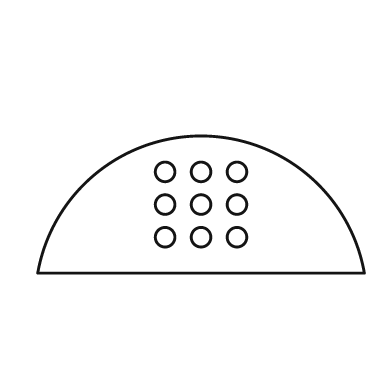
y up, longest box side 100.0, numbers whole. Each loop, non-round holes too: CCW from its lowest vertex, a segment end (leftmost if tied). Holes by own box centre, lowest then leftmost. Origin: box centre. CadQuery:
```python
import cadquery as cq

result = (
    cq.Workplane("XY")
    .moveTo(-50.0, -21.0)
    .lineTo(50.0, -21.0)
    .threePointArc((0.0, 21.0), (-50.0, -21.0))
    .close()
    .moveTo(-11.0, -10.0)
    .circle(3.0)
    .moveTo(0.0, -10.0)
    .circle(3.0)
    .moveTo(11.0, -10.0)
    .circle(3.0)
    .moveTo(-11.0, 0.0)
    .circle(3.0)
    .moveTo(0.0, 0.0)
    .circle(3.0)
    .moveTo(11.0, 0.0)
    .circle(3.0)
    .moveTo(-11.0, 10.0)
    .circle(3.0)
    .moveTo(0.0, 10.0)
    .circle(3.0)
    .moveTo(11.0, 10.0)
    .circle(3.0)
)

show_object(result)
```